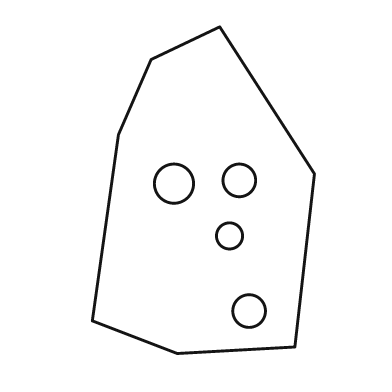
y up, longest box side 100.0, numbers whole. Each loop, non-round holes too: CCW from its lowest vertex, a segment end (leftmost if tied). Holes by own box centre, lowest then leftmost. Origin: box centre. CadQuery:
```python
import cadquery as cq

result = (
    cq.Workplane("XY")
    .moveTo(-8.0, -50.0)
    .lineTo(28.0, -48.0)
    .lineTo(34.0, 5.0)
    .lineTo(5.0, 50.0)
    .lineTo(-16.0, 40.0)
    .lineTo(-26.0, 17.0)
    .lineTo(-34.0, -40.0)
    .close()
    .moveTo(14.0, -37.0)
    .circle(5.0)
    .moveTo(8.0, -14.0)
    .circle(4.0)
    .moveTo(-9.0, 2.0)
    .circle(6.0)
    .moveTo(11.0, 3.0)
    .circle(5.0)
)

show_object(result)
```